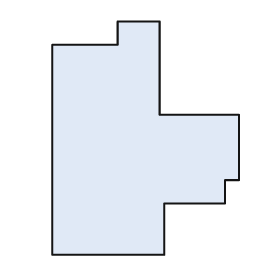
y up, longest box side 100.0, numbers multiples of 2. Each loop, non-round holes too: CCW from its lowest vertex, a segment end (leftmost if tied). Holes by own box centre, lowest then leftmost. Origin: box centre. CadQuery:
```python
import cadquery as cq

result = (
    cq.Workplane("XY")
    .moveTo(-40.0, -50.0)
    .lineTo(8.0, -50.0)
    .lineTo(8.0, -28.0)
    .lineTo(34.0, -28.0)
    .lineTo(34.0, -18.0)
    .lineTo(40.0, -18.0)
    .lineTo(40.0, 10.0)
    .lineTo(6.0, 10.0)
    .lineTo(6.0, 50.0)
    .lineTo(-12.0, 50.0)
    .lineTo(-12.0, 40.0)
    .lineTo(-40.0, 40.0)
    .close()
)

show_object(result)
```